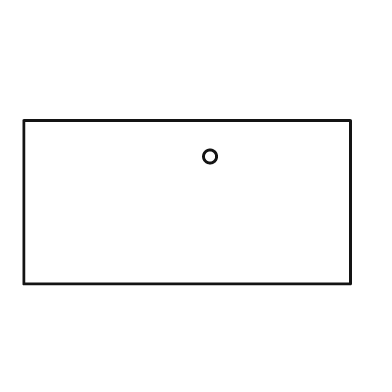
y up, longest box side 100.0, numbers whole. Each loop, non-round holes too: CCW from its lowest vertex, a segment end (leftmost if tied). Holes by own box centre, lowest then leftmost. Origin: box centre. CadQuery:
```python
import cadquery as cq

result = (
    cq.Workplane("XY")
    .moveTo(-50.0, -25.0)
    .lineTo(50.0, -25.0)
    .lineTo(50.0, 25.0)
    .lineTo(-50.0, 25.0)
    .close()
    .moveTo(7.0, 14.0)
    .circle(2.0)
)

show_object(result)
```